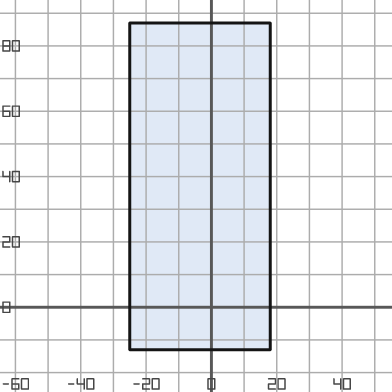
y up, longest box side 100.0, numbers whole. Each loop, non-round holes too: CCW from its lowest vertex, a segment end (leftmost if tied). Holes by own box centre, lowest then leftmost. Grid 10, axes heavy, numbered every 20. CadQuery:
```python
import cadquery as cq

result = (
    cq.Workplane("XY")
    .moveTo(-25.0, -13.0)
    .lineTo(18.0, -13.0)
    .lineTo(18.0, 87.0)
    .lineTo(-25.0, 87.0)
    .close()
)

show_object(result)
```